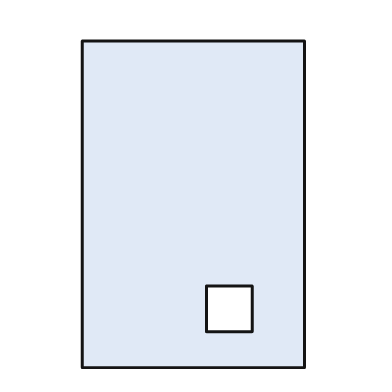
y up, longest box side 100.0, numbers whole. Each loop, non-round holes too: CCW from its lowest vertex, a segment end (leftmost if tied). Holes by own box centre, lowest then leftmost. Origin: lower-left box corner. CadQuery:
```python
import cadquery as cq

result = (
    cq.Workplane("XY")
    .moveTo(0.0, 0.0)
    .lineTo(68.0, 0.0)
    .lineTo(68.0, 100.0)
    .lineTo(0.0, 100.0)
    .close()
    .moveTo(38.0, 11.0)
    .lineTo(52.0, 11.0)
    .lineTo(52.0, 25.0)
    .lineTo(38.0, 25.0)
    .close()
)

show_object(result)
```